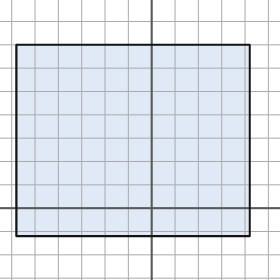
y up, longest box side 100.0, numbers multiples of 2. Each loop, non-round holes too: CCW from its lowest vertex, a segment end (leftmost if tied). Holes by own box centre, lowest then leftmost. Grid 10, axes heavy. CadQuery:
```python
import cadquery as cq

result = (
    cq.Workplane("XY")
    .moveTo(-58.0, -12.0)
    .lineTo(42.0, -12.0)
    .lineTo(42.0, 70.0)
    .lineTo(-58.0, 70.0)
    .close()
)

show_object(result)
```